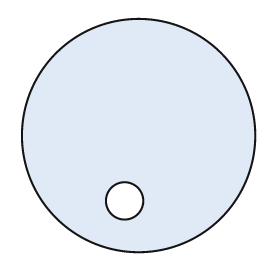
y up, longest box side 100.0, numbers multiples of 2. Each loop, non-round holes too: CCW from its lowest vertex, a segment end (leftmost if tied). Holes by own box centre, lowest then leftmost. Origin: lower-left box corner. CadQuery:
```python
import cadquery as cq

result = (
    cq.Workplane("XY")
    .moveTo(50.0, 50.0)
    .circle(50.0)
    .moveTo(44.0, 22.0)
    .circle(8.0)
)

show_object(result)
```